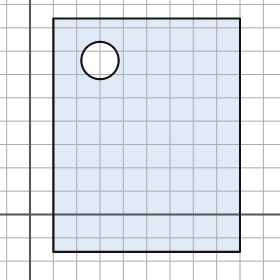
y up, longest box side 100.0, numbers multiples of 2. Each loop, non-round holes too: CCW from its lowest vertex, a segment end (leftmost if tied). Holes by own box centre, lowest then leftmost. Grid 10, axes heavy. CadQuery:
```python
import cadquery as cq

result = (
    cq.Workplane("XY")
    .moveTo(10.0, -16.0)
    .lineTo(90.0, -16.0)
    .lineTo(90.0, 84.0)
    .lineTo(10.0, 84.0)
    .close()
    .moveTo(30.0, 66.0)
    .circle(8.0)
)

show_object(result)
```